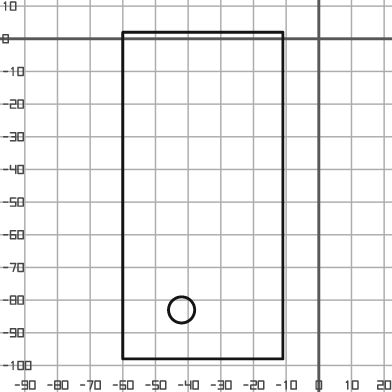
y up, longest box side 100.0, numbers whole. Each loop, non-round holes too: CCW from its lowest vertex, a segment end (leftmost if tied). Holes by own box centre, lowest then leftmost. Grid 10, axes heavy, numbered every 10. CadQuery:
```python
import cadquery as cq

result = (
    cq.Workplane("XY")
    .moveTo(-60.0, -98.0)
    .lineTo(-11.0, -98.0)
    .lineTo(-11.0, 2.0)
    .lineTo(-60.0, 2.0)
    .close()
    .moveTo(-42.0, -83.0)
    .circle(4.0)
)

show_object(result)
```